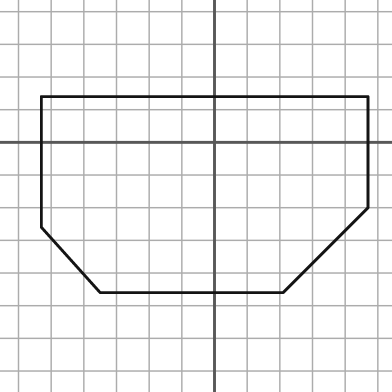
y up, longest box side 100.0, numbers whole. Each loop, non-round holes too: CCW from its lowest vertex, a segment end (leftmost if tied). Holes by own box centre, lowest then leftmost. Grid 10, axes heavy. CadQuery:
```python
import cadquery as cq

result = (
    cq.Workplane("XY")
    .moveTo(-35.0, -46.0)
    .lineTo(21.0, -46.0)
    .lineTo(47.0, -20.0)
    .lineTo(47.0, 14.0)
    .lineTo(-53.0, 14.0)
    .lineTo(-53.0, -26.0)
    .close()
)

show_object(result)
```